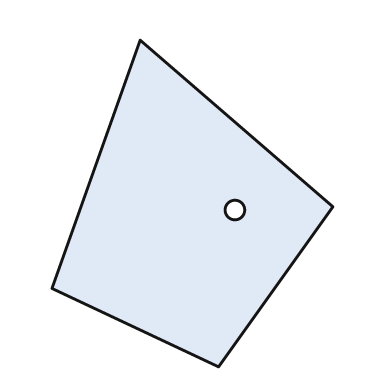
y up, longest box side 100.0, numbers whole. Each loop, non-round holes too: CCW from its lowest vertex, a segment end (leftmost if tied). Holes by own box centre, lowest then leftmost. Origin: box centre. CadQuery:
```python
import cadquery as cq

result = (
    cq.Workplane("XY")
    .moveTo(8.0, -50.0)
    .lineTo(43.0, -1.0)
    .lineTo(-16.0, 50.0)
    .lineTo(-43.0, -26.0)
    .close()
    .moveTo(13.0, -2.0)
    .circle(3.0)
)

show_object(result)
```